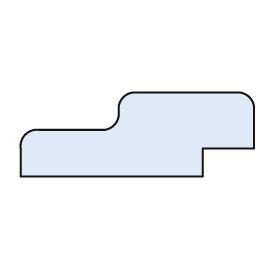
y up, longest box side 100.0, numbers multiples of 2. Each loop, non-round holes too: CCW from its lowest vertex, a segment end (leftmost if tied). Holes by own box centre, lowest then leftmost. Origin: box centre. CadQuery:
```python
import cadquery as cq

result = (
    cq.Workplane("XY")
    .moveTo(-50.0, -18.0)
    .lineTo(28.0, -18.0)
    .lineTo(28.0, -6.0)
    .lineTo(50.0, -6.0)
    .lineTo(50.0, 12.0)
    .threePointArc((48.0, 16.0), (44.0, 18.0))
    .lineTo(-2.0, 18.0)
    .threePointArc((-6.0, 16.0), (-8.0, 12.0))
    .lineTo(-8.0, 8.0)
    .threePointArc((-10.0, 4.0), (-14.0, 2.0))
    .lineTo(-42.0, 2.0)
    .threePointArc((-48.0, 0.0), (-50.0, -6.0))
    .close()
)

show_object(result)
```